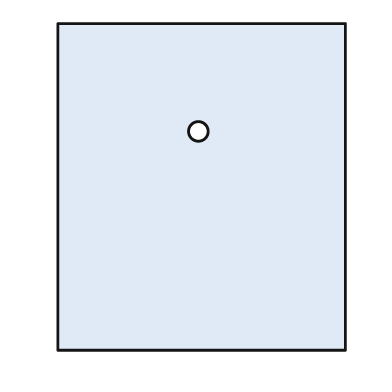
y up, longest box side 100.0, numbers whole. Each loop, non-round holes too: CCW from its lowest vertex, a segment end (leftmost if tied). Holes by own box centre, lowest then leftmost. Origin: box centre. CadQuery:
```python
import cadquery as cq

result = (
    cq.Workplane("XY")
    .moveTo(-44.0, -50.0)
    .lineTo(44.0, -50.0)
    .lineTo(44.0, 50.0)
    .lineTo(-44.0, 50.0)
    .close()
    .moveTo(-1.0, 17.0)
    .circle(3.0)
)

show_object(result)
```